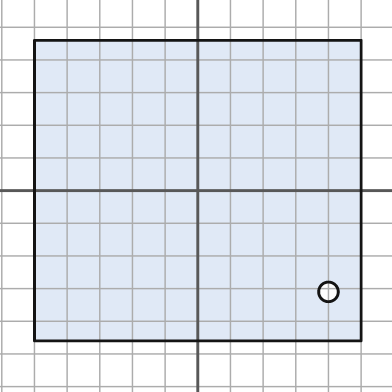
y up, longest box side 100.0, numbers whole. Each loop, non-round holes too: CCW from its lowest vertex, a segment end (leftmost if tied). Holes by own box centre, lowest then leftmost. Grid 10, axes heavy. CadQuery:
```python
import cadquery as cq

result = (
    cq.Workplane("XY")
    .moveTo(-50.0, -46.0)
    .lineTo(50.0, -46.0)
    .lineTo(50.0, 46.0)
    .lineTo(-50.0, 46.0)
    .close()
    .moveTo(40.0, -31.0)
    .circle(3.0)
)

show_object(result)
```